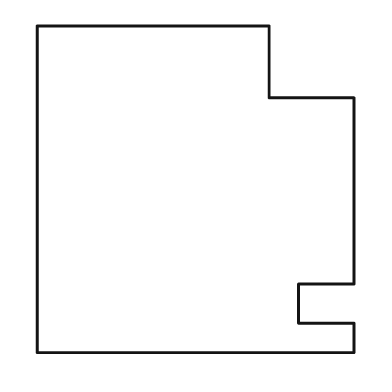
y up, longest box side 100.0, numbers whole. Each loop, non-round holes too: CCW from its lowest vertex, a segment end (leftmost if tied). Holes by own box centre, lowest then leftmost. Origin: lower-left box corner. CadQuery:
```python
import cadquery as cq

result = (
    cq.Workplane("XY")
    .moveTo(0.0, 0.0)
    .lineTo(97.0, 0.0)
    .lineTo(97.0, 9.0)
    .lineTo(80.0, 9.0)
    .lineTo(80.0, 21.0)
    .lineTo(97.0, 21.0)
    .lineTo(97.0, 78.0)
    .lineTo(71.0, 78.0)
    .lineTo(71.0, 100.0)
    .lineTo(0.0, 100.0)
    .close()
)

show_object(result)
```